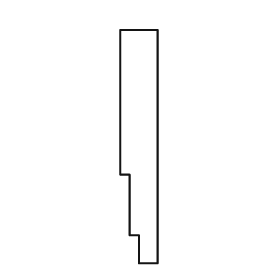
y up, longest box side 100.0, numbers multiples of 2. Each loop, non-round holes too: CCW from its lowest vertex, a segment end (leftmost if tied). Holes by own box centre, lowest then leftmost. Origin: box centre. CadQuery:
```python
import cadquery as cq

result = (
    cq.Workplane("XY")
    .moveTo(0.0, -50.0)
    .lineTo(8.0, -50.0)
    .lineTo(8.0, 50.0)
    .lineTo(-8.0, 50.0)
    .lineTo(-8.0, -12.0)
    .lineTo(-4.0, -12.0)
    .lineTo(-4.0, -38.0)
    .lineTo(0.0, -38.0)
    .close()
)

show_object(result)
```